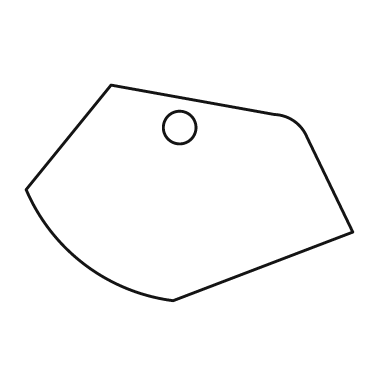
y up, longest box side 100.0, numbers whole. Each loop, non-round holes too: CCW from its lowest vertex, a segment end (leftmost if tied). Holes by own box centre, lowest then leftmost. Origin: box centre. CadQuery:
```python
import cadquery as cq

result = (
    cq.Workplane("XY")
    .moveTo(-5.0, -33.0)
    .lineTo(50.0, -12.0)
    .lineTo(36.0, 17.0)
    .threePointArc((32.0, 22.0), (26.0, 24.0))
    .lineTo(-24.0, 33.0)
    .lineTo(-50.0, 1.0)
    .threePointArc((-32.0, -22.0), (-5.0, -33.0))
    .close()
    .moveTo(-3.0, 20.0)
    .circle(5.0)
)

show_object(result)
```